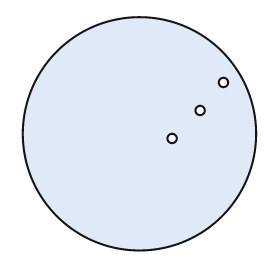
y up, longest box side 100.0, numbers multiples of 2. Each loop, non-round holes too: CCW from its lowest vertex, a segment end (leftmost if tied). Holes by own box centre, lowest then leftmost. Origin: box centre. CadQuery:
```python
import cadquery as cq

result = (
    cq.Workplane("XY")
    .moveTo(0.0, 0.0)
    .circle(50.0)
    .moveTo(14.0, -2.0)
    .circle(2.0)
    .moveTo(26.0, 10.0)
    .circle(2.0)
    .moveTo(36.0, 22.0)
    .circle(2.0)
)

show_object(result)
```